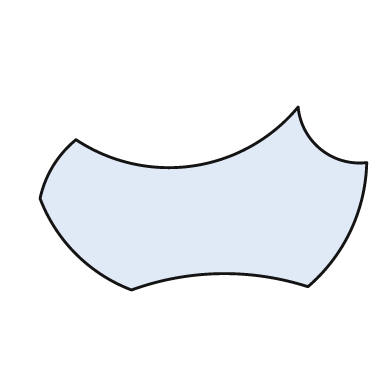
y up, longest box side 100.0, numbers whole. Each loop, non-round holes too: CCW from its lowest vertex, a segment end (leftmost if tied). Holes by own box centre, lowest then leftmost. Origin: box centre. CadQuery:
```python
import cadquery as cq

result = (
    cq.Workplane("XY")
    .moveTo(-22.0, -28.0)
    .threePointArc((5.0, -23.0), (32.0, -27.0))
    .threePointArc((45.0, -10.0), (50.0, 11.0))
    .threePointArc((36.0, 15.0), (29.0, 28.0))
    .threePointArc((-3.0, 10.0), (-39.0, 18.0))
    .threePointArc((-46.0, 10.0), (-50.0, 0.0))
    .threePointArc((-39.0, -17.0), (-22.0, -28.0))
    .close()
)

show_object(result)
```